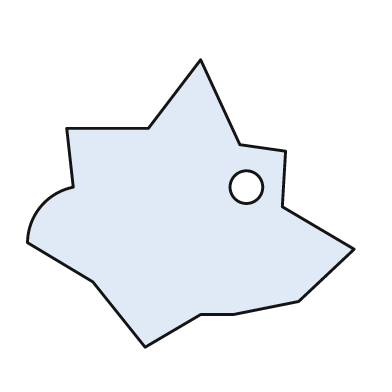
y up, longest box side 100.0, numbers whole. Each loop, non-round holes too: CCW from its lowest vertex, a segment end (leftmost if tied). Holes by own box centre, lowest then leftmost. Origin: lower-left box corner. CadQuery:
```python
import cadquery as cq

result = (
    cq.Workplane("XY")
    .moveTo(36.0, 0.0)
    .lineTo(53.0, 10.0)
    .lineTo(63.0, 10.0)
    .lineTo(83.0, 14.0)
    .lineTo(100.0, 30.0)
    .lineTo(78.0, 43.0)
    .lineTo(79.0, 60.0)
    .lineTo(65.0, 62.0)
    .lineTo(53.0, 88.0)
    .lineTo(37.0, 67.0)
    .lineTo(12.0, 67.0)
    .lineTo(14.0, 49.0)
    .threePointArc((4.0, 43.0), (0.0, 32.0))
    .lineTo(20.0, 20.0)
    .close()
    .moveTo(67.0, 49.0)
    .circle(5.0)
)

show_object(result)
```